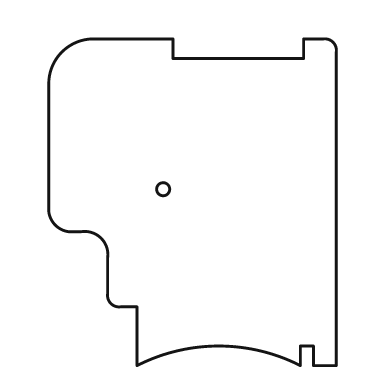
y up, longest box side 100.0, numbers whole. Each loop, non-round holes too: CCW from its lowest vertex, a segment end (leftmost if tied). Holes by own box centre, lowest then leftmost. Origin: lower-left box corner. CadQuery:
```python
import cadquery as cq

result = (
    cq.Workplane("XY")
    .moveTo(27.0, 0.0)
    .threePointArc((52.0, 6.0), (77.0, 0.0))
    .lineTo(77.0, 6.0)
    .lineTo(81.0, 6.0)
    .lineTo(81.0, 0.0)
    .lineTo(88.0, 0.0)
    .lineTo(88.0, 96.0)
    .threePointArc((87.0, 99.0), (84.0, 100.0))
    .lineTo(78.0, 100.0)
    .lineTo(78.0, 94.0)
    .lineTo(38.0, 94.0)
    .lineTo(38.0, 100.0)
    .lineTo(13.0, 100.0)
    .threePointArc((4.0, 96.0), (0.0, 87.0))
    .lineTo(0.0, 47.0)
    .threePointArc((2.0, 43.0), (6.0, 41.0))
    .lineTo(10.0, 41.0)
    .threePointArc((16.0, 39.0), (18.0, 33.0))
    .lineTo(18.0, 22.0)
    .threePointArc((19.0, 19.0), (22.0, 18.0))
    .lineTo(27.0, 18.0)
    .close()
    .moveTo(35.0, 54.0)
    .circle(2.0)
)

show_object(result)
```